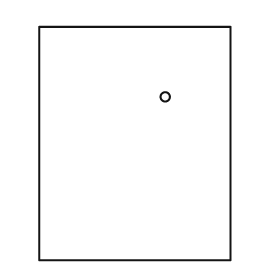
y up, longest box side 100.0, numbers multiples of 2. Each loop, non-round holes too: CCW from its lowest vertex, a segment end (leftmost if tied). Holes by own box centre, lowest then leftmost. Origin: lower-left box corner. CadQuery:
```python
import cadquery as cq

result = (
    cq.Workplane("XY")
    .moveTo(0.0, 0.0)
    .lineTo(82.0, 0.0)
    .lineTo(82.0, 100.0)
    .lineTo(0.0, 100.0)
    .close()
    .moveTo(54.0, 70.0)
    .circle(2.0)
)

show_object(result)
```